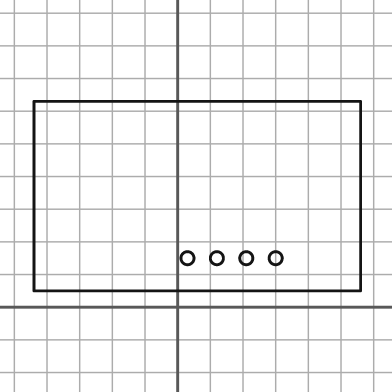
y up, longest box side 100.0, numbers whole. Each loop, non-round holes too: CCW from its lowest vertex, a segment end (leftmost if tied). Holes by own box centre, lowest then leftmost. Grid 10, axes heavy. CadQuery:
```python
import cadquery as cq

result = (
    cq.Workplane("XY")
    .moveTo(-44.0, 5.0)
    .lineTo(56.0, 5.0)
    .lineTo(56.0, 63.0)
    .lineTo(-44.0, 63.0)
    .close()
    .moveTo(3.0, 15.0)
    .circle(2.0)
    .moveTo(12.0, 15.0)
    .circle(2.0)
    .moveTo(21.0, 15.0)
    .circle(2.0)
    .moveTo(30.0, 15.0)
    .circle(2.0)
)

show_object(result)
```